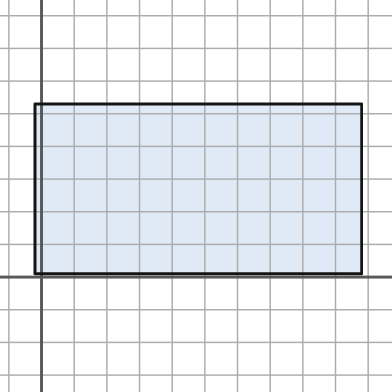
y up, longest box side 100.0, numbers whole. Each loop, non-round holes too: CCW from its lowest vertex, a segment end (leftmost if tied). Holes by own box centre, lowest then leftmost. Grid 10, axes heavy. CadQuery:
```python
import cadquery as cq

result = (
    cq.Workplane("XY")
    .moveTo(-2.0, 1.0)
    .lineTo(98.0, 1.0)
    .lineTo(98.0, 53.0)
    .lineTo(-2.0, 53.0)
    .close()
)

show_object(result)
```